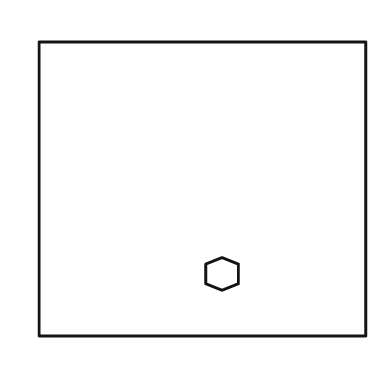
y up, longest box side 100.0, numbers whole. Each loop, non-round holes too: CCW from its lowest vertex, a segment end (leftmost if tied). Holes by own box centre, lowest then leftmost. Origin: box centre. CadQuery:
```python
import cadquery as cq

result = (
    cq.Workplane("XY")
    .moveTo(-50.0, -45.0)
    .lineTo(50.0, -45.0)
    .lineTo(50.0, 45.0)
    .lineTo(-50.0, 45.0)
    .close()
    .moveTo(6.0, -31.0)
    .lineTo(11.0, -29.0)
    .lineTo(11.0, -23.0)
    .lineTo(6.0, -21.0)
    .lineTo(1.0, -23.0)
    .lineTo(1.0, -29.0)
    .close()
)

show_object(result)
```